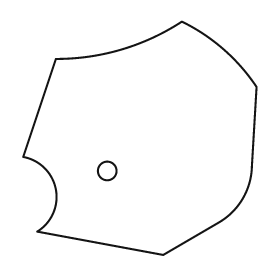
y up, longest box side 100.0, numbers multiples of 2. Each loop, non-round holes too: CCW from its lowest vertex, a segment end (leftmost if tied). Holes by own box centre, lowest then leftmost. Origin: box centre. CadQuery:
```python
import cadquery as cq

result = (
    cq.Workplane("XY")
    .moveTo(10.0, -50.0)
    .lineTo(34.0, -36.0)
    .threePointArc((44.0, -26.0), (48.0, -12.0))
    .lineTo(50.0, 22.0)
    .threePointArc((36.0, 38.0), (18.0, 50.0))
    .threePointArc((-8.0, 38.0), (-36.0, 34.0))
    .lineTo(-50.0, -8.0)
    .threePointArc((-36.0, -22.0), (-44.0, -40.0))
    .close()
    .moveTo(-14.0, -14.0)
    .circle(4.0)
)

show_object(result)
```